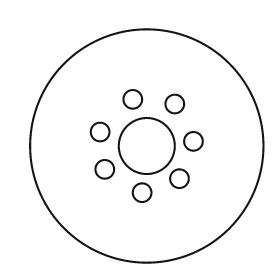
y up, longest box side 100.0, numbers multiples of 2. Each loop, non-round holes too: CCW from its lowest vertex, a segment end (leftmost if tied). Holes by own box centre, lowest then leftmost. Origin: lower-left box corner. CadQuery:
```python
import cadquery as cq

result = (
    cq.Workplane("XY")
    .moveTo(50.0, 50.0)
    .circle(50.0)
    .moveTo(48.0, 30.0)
    .circle(4.0)
    .moveTo(64.0, 36.0)
    .circle(4.0)
    .moveTo(32.0, 40.0)
    .circle(4.0)
    .moveTo(50.0, 50.0)
    .circle(12.0)
    .moveTo(70.0, 52.0)
    .circle(4.0)
    .moveTo(30.0, 56.0)
    .circle(4.0)
    .moveTo(62.0, 68.0)
    .circle(4.0)
    .moveTo(44.0, 70.0)
    .circle(4.0)
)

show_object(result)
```